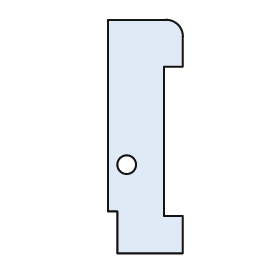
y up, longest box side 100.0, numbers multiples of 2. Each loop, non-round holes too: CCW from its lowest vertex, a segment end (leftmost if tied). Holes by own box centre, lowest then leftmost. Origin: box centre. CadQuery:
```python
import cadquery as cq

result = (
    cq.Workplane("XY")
    .moveTo(-12.0, -50.0)
    .lineTo(16.0, -50.0)
    .lineTo(16.0, -34.0)
    .lineTo(8.0, -34.0)
    .lineTo(8.0, 30.0)
    .lineTo(16.0, 30.0)
    .lineTo(16.0, 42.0)
    .threePointArc((14.0, 48.0), (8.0, 50.0))
    .lineTo(-16.0, 50.0)
    .lineTo(-16.0, -32.0)
    .lineTo(-12.0, -32.0)
    .close()
    .moveTo(-8.0, -12.0)
    .circle(4.0)
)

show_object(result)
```